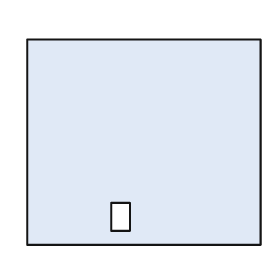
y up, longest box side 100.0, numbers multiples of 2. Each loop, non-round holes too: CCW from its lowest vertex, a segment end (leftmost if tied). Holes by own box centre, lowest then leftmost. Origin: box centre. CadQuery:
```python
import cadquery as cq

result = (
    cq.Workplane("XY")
    .moveTo(-50.0, -44.0)
    .lineTo(50.0, -44.0)
    .lineTo(50.0, 44.0)
    .lineTo(-50.0, 44.0)
    .close()
    .moveTo(-14.0, -38.0)
    .lineTo(-6.0, -38.0)
    .lineTo(-6.0, -26.0)
    .lineTo(-14.0, -26.0)
    .close()
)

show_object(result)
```